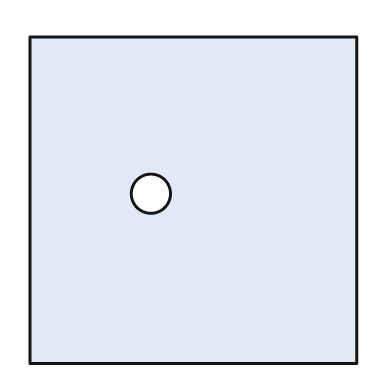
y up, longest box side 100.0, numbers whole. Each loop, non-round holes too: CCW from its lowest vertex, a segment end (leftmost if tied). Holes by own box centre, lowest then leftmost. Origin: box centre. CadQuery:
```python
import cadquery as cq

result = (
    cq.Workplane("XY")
    .moveTo(-50.0, -50.0)
    .lineTo(50.0, -50.0)
    .lineTo(50.0, 50.0)
    .lineTo(-50.0, 50.0)
    .close()
    .moveTo(-13.0, 2.0)
    .circle(6.0)
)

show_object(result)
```